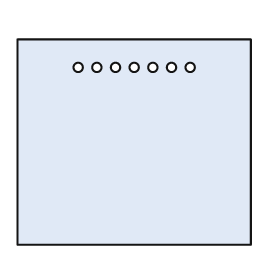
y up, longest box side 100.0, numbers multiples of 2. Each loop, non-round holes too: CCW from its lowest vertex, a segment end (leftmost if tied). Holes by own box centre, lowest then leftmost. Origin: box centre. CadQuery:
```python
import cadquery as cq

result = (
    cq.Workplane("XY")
    .moveTo(-50.0, -44.0)
    .lineTo(50.0, -44.0)
    .lineTo(50.0, 44.0)
    .lineTo(-50.0, 44.0)
    .close()
    .moveTo(-24.0, 32.0)
    .circle(2.0)
    .moveTo(-16.0, 32.0)
    .circle(2.0)
    .moveTo(-8.0, 32.0)
    .circle(2.0)
    .moveTo(0.0, 32.0)
    .circle(2.0)
    .moveTo(8.0, 32.0)
    .circle(2.0)
    .moveTo(16.0, 32.0)
    .circle(2.0)
    .moveTo(24.0, 32.0)
    .circle(2.0)
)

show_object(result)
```